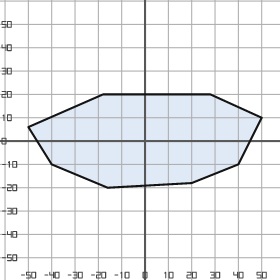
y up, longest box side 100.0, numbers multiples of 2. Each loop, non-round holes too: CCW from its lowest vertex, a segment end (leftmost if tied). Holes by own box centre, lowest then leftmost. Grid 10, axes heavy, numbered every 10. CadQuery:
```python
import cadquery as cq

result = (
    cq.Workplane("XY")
    .moveTo(-16.0, -20.0)
    .lineTo(20.0, -18.0)
    .lineTo(40.0, -10.0)
    .lineTo(50.0, 10.0)
    .lineTo(28.0, 20.0)
    .lineTo(-18.0, 20.0)
    .lineTo(-50.0, 6.0)
    .lineTo(-40.0, -10.0)
    .close()
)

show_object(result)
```